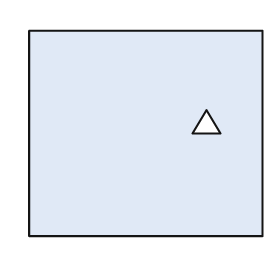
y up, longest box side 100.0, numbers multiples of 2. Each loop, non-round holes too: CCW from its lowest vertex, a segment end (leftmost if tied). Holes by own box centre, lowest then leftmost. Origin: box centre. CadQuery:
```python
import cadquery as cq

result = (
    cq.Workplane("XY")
    .moveTo(-50.0, -44.0)
    .lineTo(50.0, -44.0)
    .lineTo(50.0, 44.0)
    .lineTo(-50.0, 44.0)
    .close()
    .moveTo(20.0, 0.0)
    .lineTo(32.0, 0.0)
    .lineTo(26.0, 10.0)
    .close()
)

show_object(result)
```